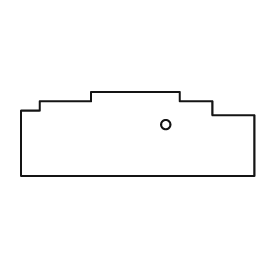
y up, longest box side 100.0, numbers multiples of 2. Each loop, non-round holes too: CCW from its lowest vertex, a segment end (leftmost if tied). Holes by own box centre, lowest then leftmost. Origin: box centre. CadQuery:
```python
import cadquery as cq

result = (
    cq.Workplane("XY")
    .moveTo(-50.0, -18.0)
    .lineTo(50.0, -18.0)
    .lineTo(50.0, 8.0)
    .lineTo(32.0, 8.0)
    .lineTo(32.0, 14.0)
    .lineTo(18.0, 14.0)
    .lineTo(18.0, 18.0)
    .lineTo(-20.0, 18.0)
    .lineTo(-20.0, 14.0)
    .lineTo(-42.0, 14.0)
    .lineTo(-42.0, 10.0)
    .lineTo(-50.0, 10.0)
    .close()
    .moveTo(12.0, 4.0)
    .circle(2.0)
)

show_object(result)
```